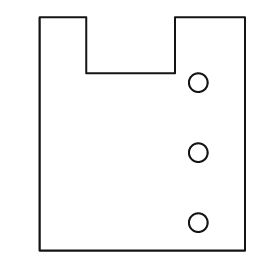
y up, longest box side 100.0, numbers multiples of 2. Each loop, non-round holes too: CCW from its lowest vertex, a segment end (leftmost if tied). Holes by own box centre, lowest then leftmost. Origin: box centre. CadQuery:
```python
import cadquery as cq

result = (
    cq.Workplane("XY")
    .moveTo(-44.0, -50.0)
    .lineTo(44.0, -50.0)
    .lineTo(44.0, 50.0)
    .lineTo(14.0, 50.0)
    .lineTo(14.0, 26.0)
    .lineTo(-24.0, 26.0)
    .lineTo(-24.0, 50.0)
    .lineTo(-44.0, 50.0)
    .close()
    .moveTo(24.0, -38.0)
    .circle(4.0)
    .moveTo(24.0, -8.0)
    .circle(4.0)
    .moveTo(24.0, 22.0)
    .circle(4.0)
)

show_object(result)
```